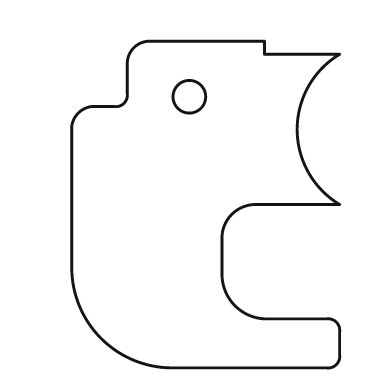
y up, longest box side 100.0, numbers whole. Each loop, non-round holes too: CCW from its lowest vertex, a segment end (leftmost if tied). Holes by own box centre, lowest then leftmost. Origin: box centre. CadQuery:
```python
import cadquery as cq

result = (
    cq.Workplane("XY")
    .moveTo(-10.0, -50.0)
    .lineTo(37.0, -50.0)
    .threePointArc((40.0, -49.0), (41.0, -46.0))
    .lineTo(41.0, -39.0)
    .threePointArc((40.0, -36.0), (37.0, -35.0))
    .lineTo(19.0, -35.0)
    .threePointArc((9.0, -31.0), (5.0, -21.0))
    .lineTo(5.0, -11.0)
    .threePointArc((8.0, -3.0), (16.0, 0.0))
    .lineTo(41.0, 0.0)
    .threePointArc((28.0, 23.0), (41.0, 46.0))
    .lineTo(18.0, 46.0)
    .lineTo(18.0, 50.0)
    .lineTo(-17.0, 50.0)
    .threePointArc((-22.0, 48.0), (-24.0, 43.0))
    .lineTo(-24.0, 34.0)
    .threePointArc((-25.0, 31.0), (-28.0, 30.0))
    .lineTo(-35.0, 30.0)
    .threePointArc((-39.0, 28.0), (-41.0, 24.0))
    .lineTo(-41.0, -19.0)
    .threePointArc((-32.0, -41.0), (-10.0, -50.0))
    .close()
    .moveTo(-5.0, 33.0)
    .circle(5.0)
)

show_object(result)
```